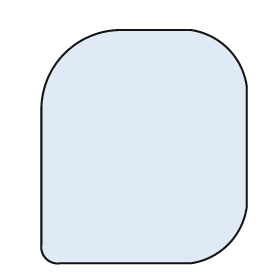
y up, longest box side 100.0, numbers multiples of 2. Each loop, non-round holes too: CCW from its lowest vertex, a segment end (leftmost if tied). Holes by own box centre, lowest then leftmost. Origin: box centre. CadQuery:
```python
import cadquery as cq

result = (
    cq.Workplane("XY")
    .moveTo(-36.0, -50.0)
    .lineTo(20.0, -50.0)
    .threePointArc((36.0, -42.0), (44.0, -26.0))
    .lineTo(44.0, 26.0)
    .threePointArc((36.0, 42.0), (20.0, 50.0))
    .lineTo(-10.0, 50.0)
    .threePointArc((-34.0, 40.0), (-44.0, 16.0))
    .lineTo(-44.0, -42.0)
    .threePointArc((-42.0, -48.0), (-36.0, -50.0))
    .close()
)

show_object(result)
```